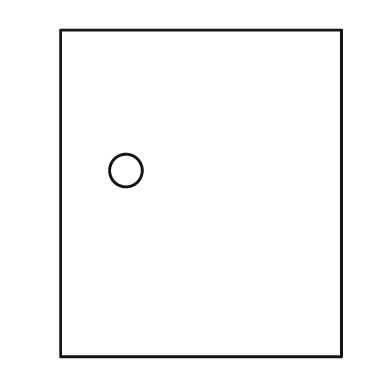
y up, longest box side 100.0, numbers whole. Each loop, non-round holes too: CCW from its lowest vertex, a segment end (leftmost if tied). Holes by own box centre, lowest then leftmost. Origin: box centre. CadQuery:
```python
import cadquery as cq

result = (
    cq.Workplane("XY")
    .moveTo(-43.0, -50.0)
    .lineTo(43.0, -50.0)
    .lineTo(43.0, 50.0)
    .lineTo(-43.0, 50.0)
    .close()
    .moveTo(-23.0, 7.0)
    .circle(5.0)
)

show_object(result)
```